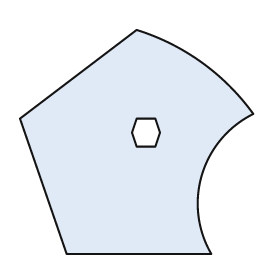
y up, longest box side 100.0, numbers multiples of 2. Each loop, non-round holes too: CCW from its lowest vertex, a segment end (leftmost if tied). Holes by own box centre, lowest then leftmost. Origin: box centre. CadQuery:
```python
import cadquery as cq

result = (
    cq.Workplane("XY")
    .moveTo(-30.0, -48.0)
    .lineTo(32.0, -48.0)
    .threePointArc((28.0, -14.0), (50.0, 12.0))
    .threePointArc((28.0, 34.0), (0.0, 48.0))
    .lineTo(-50.0, 10.0)
    .close()
    .moveTo(0.0, -2.0)
    .lineTo(8.0, -2.0)
    .lineTo(10.0, 4.0)
    .lineTo(8.0, 10.0)
    .lineTo(0.0, 10.0)
    .lineTo(-2.0, 4.0)
    .close()
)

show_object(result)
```